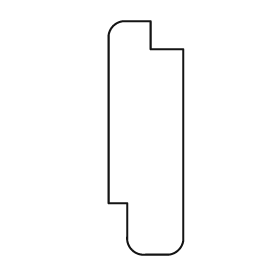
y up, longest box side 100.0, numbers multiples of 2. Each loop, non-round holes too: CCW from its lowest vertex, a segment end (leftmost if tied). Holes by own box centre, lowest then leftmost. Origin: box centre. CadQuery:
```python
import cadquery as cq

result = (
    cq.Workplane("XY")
    .moveTo(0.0, -50.0)
    .lineTo(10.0, -50.0)
    .threePointArc((14.0, -48.0), (16.0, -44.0))
    .lineTo(16.0, 38.0)
    .lineTo(2.0, 38.0)
    .lineTo(2.0, 50.0)
    .lineTo(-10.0, 50.0)
    .threePointArc((-14.0, 48.0), (-16.0, 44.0))
    .lineTo(-16.0, -28.0)
    .lineTo(-8.0, -28.0)
    .lineTo(-8.0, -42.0)
    .threePointArc((-6.0, -48.0), (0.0, -50.0))
    .close()
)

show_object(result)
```